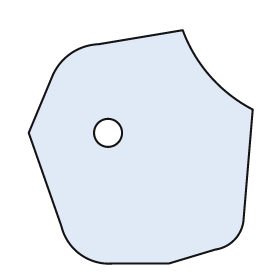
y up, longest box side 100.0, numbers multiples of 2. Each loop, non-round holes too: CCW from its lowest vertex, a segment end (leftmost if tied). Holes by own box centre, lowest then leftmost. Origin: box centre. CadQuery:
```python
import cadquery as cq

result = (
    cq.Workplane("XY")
    .moveTo(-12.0, -50.0)
    .lineTo(12.0, -50.0)
    .lineTo(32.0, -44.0)
    .threePointArc((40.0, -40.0), (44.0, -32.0))
    .lineTo(48.0, 16.0)
    .threePointArc((30.0, 30.0), (18.0, 50.0))
    .lineTo(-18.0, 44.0)
    .threePointArc((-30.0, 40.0), (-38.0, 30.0))
    .lineTo(-48.0, 6.0)
    .lineTo(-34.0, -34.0)
    .threePointArc((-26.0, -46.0), (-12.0, -50.0))
    .close()
    .moveTo(-14.0, 6.0)
    .circle(6.0)
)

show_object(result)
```